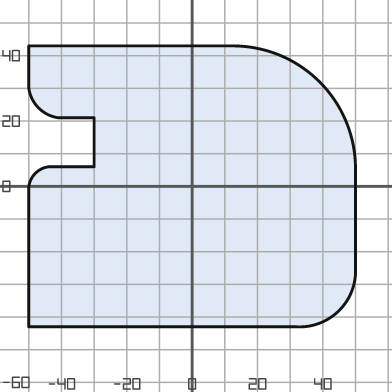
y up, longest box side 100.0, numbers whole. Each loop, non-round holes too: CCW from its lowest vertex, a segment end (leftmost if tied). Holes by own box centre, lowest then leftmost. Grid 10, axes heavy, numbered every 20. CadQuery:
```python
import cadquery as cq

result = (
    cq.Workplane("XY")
    .moveTo(-50.0, -43.0)
    .lineTo(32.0, -43.0)
    .threePointArc((45.0, -38.0), (50.0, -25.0))
    .lineTo(50.0, 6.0)
    .threePointArc((39.0, 32.0), (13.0, 43.0))
    .lineTo(-50.0, 43.0)
    .lineTo(-50.0, 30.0)
    .threePointArc((-47.0, 24.0), (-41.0, 21.0))
    .lineTo(-30.0, 21.0)
    .lineTo(-30.0, 6.0)
    .lineTo(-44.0, 6.0)
    .threePointArc((-48.0, 4.0), (-50.0, 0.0))
    .close()
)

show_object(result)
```